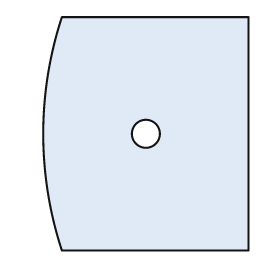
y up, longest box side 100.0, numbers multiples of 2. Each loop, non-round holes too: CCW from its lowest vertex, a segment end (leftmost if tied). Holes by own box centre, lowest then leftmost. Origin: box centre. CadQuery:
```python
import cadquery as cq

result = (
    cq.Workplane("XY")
    .moveTo(-36.0, -50.0)
    .lineTo(44.0, -50.0)
    .lineTo(44.0, 50.0)
    .lineTo(-36.0, 50.0)
    .threePointArc((-44.0, 0.0), (-36.0, -50.0))
    .close()
    .moveTo(0.0, 0.0)
    .circle(6.0)
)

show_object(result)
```